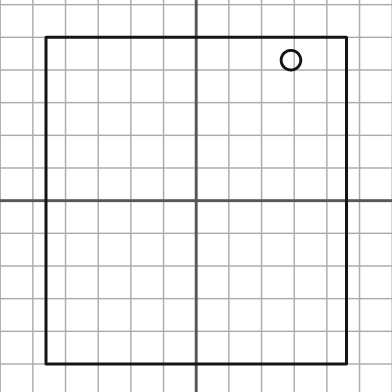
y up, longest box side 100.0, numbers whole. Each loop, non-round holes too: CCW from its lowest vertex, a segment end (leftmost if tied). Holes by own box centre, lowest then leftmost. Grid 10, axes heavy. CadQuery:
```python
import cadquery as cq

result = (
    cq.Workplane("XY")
    .moveTo(-46.0, -50.0)
    .lineTo(46.0, -50.0)
    .lineTo(46.0, 50.0)
    .lineTo(-46.0, 50.0)
    .close()
    .moveTo(29.0, 43.0)
    .circle(3.0)
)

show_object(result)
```